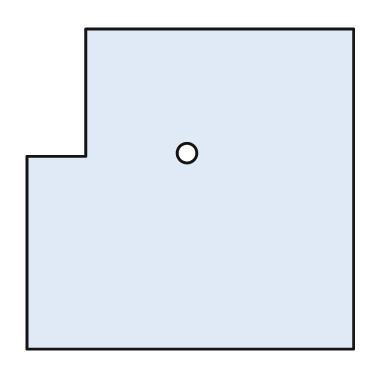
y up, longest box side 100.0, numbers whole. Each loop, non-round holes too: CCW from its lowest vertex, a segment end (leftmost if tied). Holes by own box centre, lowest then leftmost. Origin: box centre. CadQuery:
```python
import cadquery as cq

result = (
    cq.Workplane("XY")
    .moveTo(-50.0, -49.0)
    .lineTo(50.0, -49.0)
    .lineTo(50.0, 49.0)
    .lineTo(-32.0, 49.0)
    .lineTo(-32.0, 10.0)
    .lineTo(-50.0, 10.0)
    .close()
    .moveTo(-1.0, 11.0)
    .circle(3.0)
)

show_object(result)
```